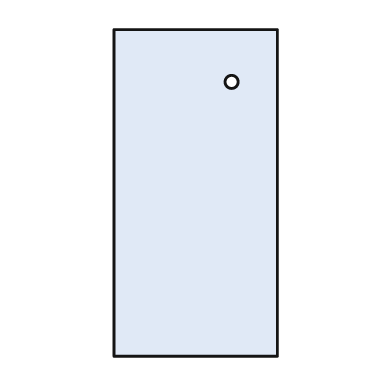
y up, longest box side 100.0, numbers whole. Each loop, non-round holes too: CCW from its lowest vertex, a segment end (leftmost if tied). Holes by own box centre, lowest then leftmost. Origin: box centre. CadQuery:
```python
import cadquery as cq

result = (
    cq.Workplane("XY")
    .moveTo(-25.0, -50.0)
    .lineTo(25.0, -50.0)
    .lineTo(25.0, 50.0)
    .lineTo(-25.0, 50.0)
    .close()
    .moveTo(11.0, 34.0)
    .circle(2.0)
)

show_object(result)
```